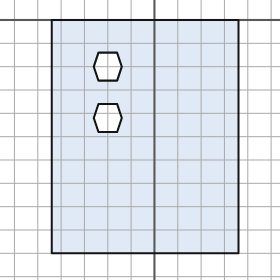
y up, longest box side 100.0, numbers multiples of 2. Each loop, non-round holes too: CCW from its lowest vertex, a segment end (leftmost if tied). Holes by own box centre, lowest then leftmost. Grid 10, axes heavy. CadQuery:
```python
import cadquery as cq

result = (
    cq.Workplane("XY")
    .moveTo(-44.0, -100.0)
    .lineTo(36.0, -100.0)
    .lineTo(36.0, 0.0)
    .lineTo(-44.0, 0.0)
    .close()
    .moveTo(-24.0, -48.0)
    .lineTo(-16.0, -48.0)
    .lineTo(-14.0, -42.0)
    .lineTo(-16.0, -36.0)
    .lineTo(-24.0, -36.0)
    .lineTo(-26.0, -42.0)
    .close()
    .moveTo(-24.0, -26.0)
    .lineTo(-16.0, -26.0)
    .lineTo(-14.0, -20.0)
    .lineTo(-16.0, -14.0)
    .lineTo(-24.0, -14.0)
    .lineTo(-26.0, -20.0)
    .close()
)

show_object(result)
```